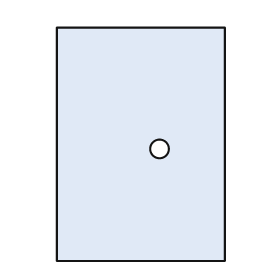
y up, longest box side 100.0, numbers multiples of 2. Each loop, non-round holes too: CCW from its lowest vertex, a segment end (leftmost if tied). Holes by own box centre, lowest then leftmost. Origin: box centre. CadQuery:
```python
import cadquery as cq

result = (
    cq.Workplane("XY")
    .moveTo(-36.0, -50.0)
    .lineTo(36.0, -50.0)
    .lineTo(36.0, 50.0)
    .lineTo(-36.0, 50.0)
    .close()
    .moveTo(8.0, -2.0)
    .circle(4.0)
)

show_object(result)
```